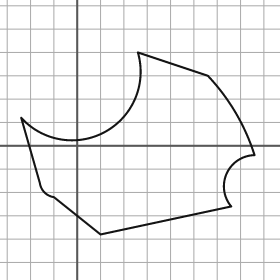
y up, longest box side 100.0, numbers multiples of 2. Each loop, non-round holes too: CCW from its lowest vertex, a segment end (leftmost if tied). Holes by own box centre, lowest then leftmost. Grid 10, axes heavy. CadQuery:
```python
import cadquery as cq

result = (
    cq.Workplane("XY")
    .moveTo(10.0, -38.0)
    .lineTo(66.0, -26.0)
    .threePointArc((64.0, -12.0), (76.0, -4.0))
    .threePointArc((68.0, 14.0), (56.0, 30.0))
    .lineTo(26.0, 40.0)
    .threePointArc((12.0, 6.0), (-24.0, 12.0))
    .lineTo(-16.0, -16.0)
    .threePointArc((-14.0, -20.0), (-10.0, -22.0))
    .close()
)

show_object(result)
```